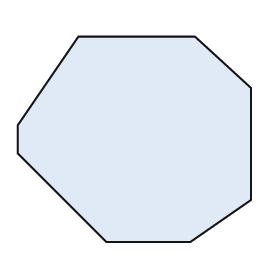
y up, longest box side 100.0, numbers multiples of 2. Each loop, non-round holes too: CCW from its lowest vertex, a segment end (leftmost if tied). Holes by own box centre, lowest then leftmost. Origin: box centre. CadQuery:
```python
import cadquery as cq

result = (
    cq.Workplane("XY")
    .moveTo(-12.0, -44.0)
    .lineTo(24.0, -44.0)
    .lineTo(50.0, -26.0)
    .lineTo(50.0, 22.0)
    .lineTo(26.0, 44.0)
    .lineTo(-24.0, 44.0)
    .lineTo(-50.0, 6.0)
    .lineTo(-50.0, -6.0)
    .close()
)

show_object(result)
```